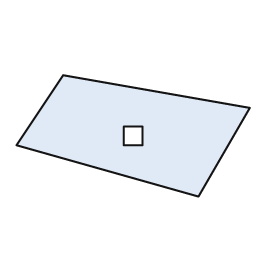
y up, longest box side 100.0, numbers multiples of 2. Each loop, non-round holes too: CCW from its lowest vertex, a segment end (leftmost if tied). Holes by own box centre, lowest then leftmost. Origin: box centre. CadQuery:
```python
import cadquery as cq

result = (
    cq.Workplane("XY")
    .moveTo(28.0, -26.0)
    .lineTo(50.0, 12.0)
    .lineTo(-30.0, 26.0)
    .lineTo(-50.0, -4.0)
    .close()
    .moveTo(-4.0, -4.0)
    .lineTo(4.0, -4.0)
    .lineTo(4.0, 4.0)
    .lineTo(-4.0, 4.0)
    .close()
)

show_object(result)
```